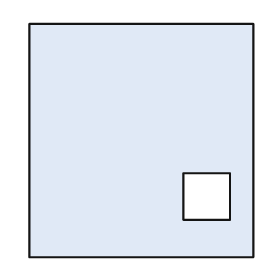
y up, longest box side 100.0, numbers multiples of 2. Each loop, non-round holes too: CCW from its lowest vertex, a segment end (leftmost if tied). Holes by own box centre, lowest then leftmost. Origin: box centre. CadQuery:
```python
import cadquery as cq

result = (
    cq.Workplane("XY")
    .moveTo(-48.0, -50.0)
    .lineTo(48.0, -50.0)
    .lineTo(48.0, 50.0)
    .lineTo(-48.0, 50.0)
    .close()
    .moveTo(18.0, -34.0)
    .lineTo(38.0, -34.0)
    .lineTo(38.0, -14.0)
    .lineTo(18.0, -14.0)
    .close()
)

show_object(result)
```